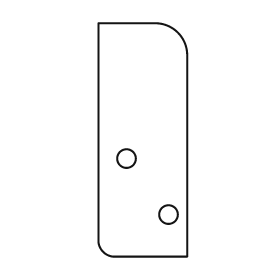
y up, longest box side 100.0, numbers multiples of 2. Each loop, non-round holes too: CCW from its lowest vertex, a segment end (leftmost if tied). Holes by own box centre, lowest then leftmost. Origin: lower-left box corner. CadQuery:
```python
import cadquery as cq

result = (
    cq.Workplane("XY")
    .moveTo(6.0, 0.0)
    .lineTo(38.0, 0.0)
    .lineTo(38.0, 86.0)
    .threePointArc((34.0, 96.0), (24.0, 100.0))
    .lineTo(0.0, 100.0)
    .lineTo(0.0, 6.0)
    .threePointArc((2.0, 2.0), (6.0, 0.0))
    .close()
    .moveTo(30.0, 18.0)
    .circle(4.0)
    .moveTo(12.0, 42.0)
    .circle(4.0)
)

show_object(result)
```